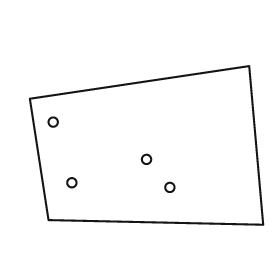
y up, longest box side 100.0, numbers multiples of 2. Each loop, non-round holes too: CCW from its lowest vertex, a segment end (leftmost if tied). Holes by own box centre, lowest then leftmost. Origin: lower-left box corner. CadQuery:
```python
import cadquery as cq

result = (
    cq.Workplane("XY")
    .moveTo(100.0, 0.0)
    .lineTo(94.0, 68.0)
    .lineTo(0.0, 54.0)
    .lineTo(8.0, 2.0)
    .close()
    .moveTo(60.0, 16.0)
    .circle(2.0)
    .moveTo(18.0, 18.0)
    .circle(2.0)
    .moveTo(50.0, 28.0)
    .circle(2.0)
    .moveTo(10.0, 44.0)
    .circle(2.0)
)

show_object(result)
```